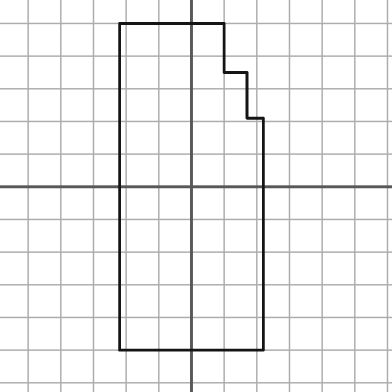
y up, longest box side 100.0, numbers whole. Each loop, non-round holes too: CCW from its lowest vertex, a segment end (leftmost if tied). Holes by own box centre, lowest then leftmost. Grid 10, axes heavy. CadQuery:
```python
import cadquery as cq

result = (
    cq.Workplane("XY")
    .moveTo(-22.0, -50.0)
    .lineTo(22.0, -50.0)
    .lineTo(22.0, 21.0)
    .lineTo(17.0, 21.0)
    .lineTo(17.0, 35.0)
    .lineTo(10.0, 35.0)
    .lineTo(10.0, 50.0)
    .lineTo(-22.0, 50.0)
    .close()
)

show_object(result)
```